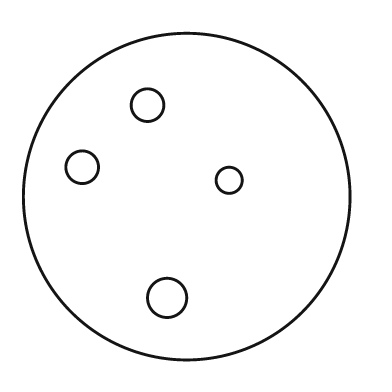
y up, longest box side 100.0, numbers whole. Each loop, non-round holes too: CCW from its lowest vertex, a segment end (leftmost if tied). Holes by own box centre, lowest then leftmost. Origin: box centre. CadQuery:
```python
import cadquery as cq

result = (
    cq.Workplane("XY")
    .moveTo(0.0, 0.0)
    .circle(50.0)
    .moveTo(-6.0, -31.0)
    .circle(6.0)
    .moveTo(13.0, 5.0)
    .circle(4.0)
    .moveTo(-32.0, 9.0)
    .circle(5.0)
    .moveTo(-12.0, 28.0)
    .circle(5.0)
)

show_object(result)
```